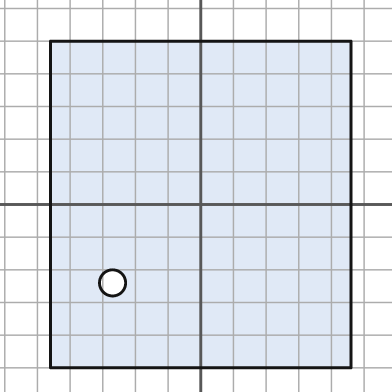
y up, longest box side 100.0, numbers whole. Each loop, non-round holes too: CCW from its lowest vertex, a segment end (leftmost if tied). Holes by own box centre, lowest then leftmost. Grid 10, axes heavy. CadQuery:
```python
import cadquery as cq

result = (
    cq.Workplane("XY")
    .moveTo(-46.0, -50.0)
    .lineTo(46.0, -50.0)
    .lineTo(46.0, 50.0)
    .lineTo(-46.0, 50.0)
    .close()
    .moveTo(-27.0, -24.0)
    .circle(4.0)
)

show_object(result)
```